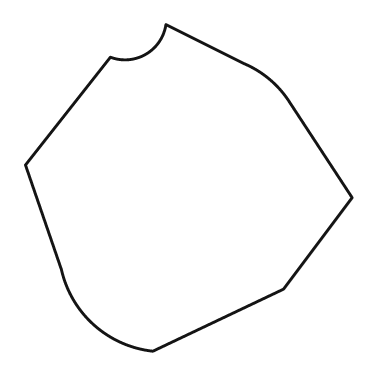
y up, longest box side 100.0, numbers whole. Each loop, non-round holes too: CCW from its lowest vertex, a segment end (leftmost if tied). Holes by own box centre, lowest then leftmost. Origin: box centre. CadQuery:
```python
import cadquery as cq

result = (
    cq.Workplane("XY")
    .moveTo(-11.0, -50.0)
    .lineTo(29.0, -31.0)
    .lineTo(50.0, -3.0)
    .lineTo(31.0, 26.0)
    .threePointArc((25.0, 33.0), (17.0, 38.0))
    .lineTo(-7.0, 50.0)
    .threePointArc((-13.0, 41.0), (-24.0, 40.0))
    .lineTo(-50.0, 7.0)
    .lineTo(-39.0, -25.0)
    .threePointArc((-29.0, -42.0), (-11.0, -50.0))
    .close()
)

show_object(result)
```